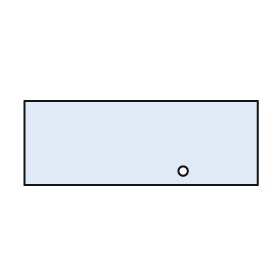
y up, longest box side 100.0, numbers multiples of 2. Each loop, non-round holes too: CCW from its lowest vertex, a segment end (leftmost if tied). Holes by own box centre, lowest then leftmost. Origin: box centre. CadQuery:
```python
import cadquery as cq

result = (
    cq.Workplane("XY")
    .moveTo(-50.0, -18.0)
    .lineTo(50.0, -18.0)
    .lineTo(50.0, 18.0)
    .lineTo(-50.0, 18.0)
    .close()
    .moveTo(18.0, -12.0)
    .circle(2.0)
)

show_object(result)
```